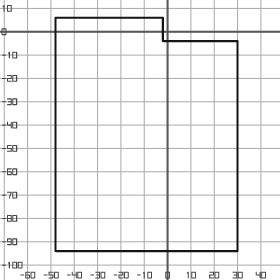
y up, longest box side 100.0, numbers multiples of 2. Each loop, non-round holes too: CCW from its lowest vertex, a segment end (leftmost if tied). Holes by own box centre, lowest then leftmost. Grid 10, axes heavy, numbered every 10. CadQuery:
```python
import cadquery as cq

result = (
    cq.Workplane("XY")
    .moveTo(-48.0, -94.0)
    .lineTo(30.0, -94.0)
    .lineTo(30.0, -4.0)
    .lineTo(-2.0, -4.0)
    .lineTo(-2.0, 6.0)
    .lineTo(-48.0, 6.0)
    .close()
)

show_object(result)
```